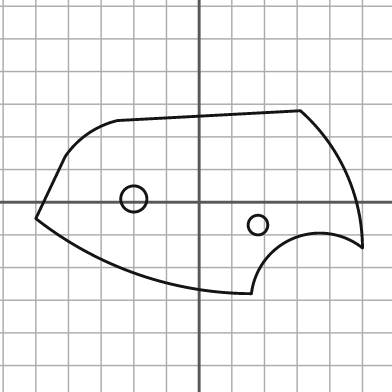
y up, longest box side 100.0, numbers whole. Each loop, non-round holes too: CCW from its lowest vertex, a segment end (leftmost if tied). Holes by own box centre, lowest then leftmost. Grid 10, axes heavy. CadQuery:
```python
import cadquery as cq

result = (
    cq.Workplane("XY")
    .moveTo(16.0, -28.0)
    .threePointArc((29.0, -11.0), (50.0, -14.0))
    .threePointArc((45.0, 9.0), (31.0, 28.0))
    .lineTo(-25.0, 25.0)
    .threePointArc((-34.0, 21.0), (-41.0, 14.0))
    .lineTo(-50.0, -5.0)
    .threePointArc((-19.0, -22.0), (16.0, -28.0))
    .close()
    .moveTo(18.0, -7.0)
    .circle(3.0)
    .moveTo(-20.0, 1.0)
    .circle(4.0)
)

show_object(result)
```